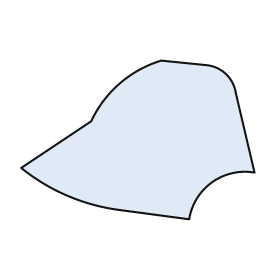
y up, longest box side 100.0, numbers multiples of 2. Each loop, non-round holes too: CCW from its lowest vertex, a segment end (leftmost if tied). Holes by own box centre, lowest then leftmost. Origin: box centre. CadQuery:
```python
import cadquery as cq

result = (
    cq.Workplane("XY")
    .moveTo(22.0, -34.0)
    .threePointArc((32.0, -18.0), (50.0, -14.0))
    .lineTo(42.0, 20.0)
    .threePointArc((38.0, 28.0), (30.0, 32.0))
    .lineTo(10.0, 34.0)
    .threePointArc((-8.0, 24.0), (-20.0, 8.0))
    .lineTo(-50.0, -12.0)
    .threePointArc((-30.0, -24.0), (-8.0, -30.0))
    .close()
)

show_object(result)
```